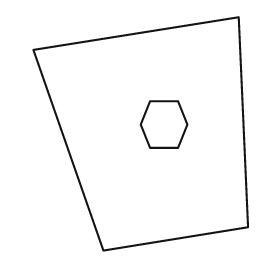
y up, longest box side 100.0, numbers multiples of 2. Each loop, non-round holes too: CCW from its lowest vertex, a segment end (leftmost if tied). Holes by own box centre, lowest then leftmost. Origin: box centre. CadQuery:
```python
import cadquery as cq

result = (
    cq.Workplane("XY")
    .moveTo(-16.0, -50.0)
    .lineTo(46.0, -40.0)
    .lineTo(42.0, 50.0)
    .lineTo(-46.0, 36.0)
    .close()
    .moveTo(4.0, -6.0)
    .lineTo(16.0, -6.0)
    .lineTo(20.0, 4.0)
    .lineTo(16.0, 14.0)
    .lineTo(4.0, 14.0)
    .lineTo(0.0, 4.0)
    .close()
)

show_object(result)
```